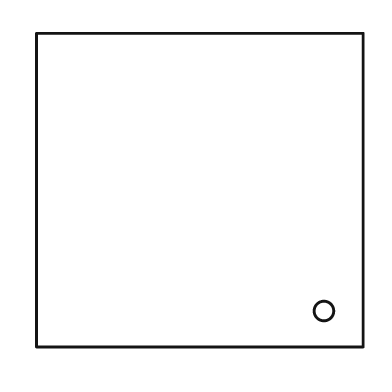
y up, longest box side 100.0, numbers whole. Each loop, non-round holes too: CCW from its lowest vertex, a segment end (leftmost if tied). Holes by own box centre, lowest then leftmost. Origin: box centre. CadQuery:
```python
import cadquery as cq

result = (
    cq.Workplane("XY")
    .moveTo(-50.0, -48.0)
    .lineTo(50.0, -48.0)
    .lineTo(50.0, 48.0)
    .lineTo(-50.0, 48.0)
    .close()
    .moveTo(38.0, -37.0)
    .circle(3.0)
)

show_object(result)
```